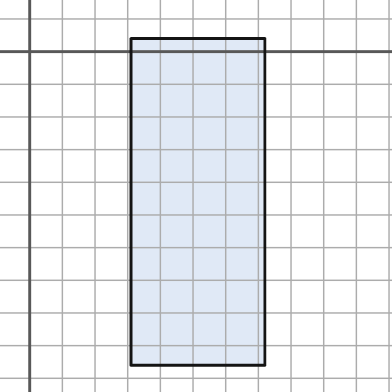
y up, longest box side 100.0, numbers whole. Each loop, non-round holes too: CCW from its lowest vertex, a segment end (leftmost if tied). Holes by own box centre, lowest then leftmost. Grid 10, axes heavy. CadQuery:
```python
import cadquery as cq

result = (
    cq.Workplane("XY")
    .moveTo(31.0, -96.0)
    .lineTo(72.0, -96.0)
    .lineTo(72.0, 4.0)
    .lineTo(31.0, 4.0)
    .close()
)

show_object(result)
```